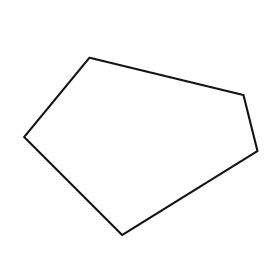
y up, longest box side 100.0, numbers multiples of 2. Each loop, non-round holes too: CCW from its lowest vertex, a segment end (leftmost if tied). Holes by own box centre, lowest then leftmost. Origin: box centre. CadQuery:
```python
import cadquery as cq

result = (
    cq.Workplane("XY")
    .moveTo(-8.0, -38.0)
    .lineTo(50.0, -2.0)
    .lineTo(44.0, 22.0)
    .lineTo(-22.0, 38.0)
    .lineTo(-50.0, 4.0)
    .close()
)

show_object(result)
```